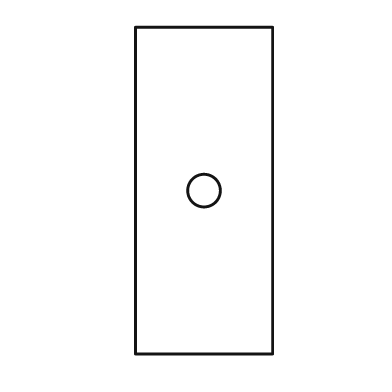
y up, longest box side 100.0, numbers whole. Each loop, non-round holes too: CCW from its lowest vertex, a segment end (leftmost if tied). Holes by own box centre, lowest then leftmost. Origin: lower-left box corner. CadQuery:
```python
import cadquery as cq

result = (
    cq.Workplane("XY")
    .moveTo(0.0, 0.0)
    .lineTo(42.0, 0.0)
    .lineTo(42.0, 100.0)
    .lineTo(0.0, 100.0)
    .close()
    .moveTo(21.0, 50.0)
    .circle(5.0)
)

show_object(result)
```